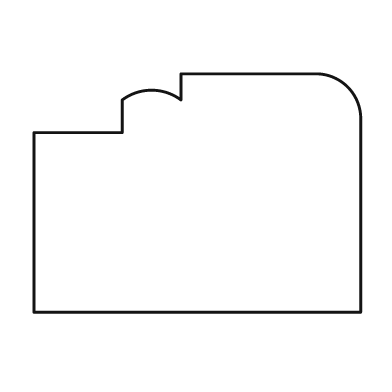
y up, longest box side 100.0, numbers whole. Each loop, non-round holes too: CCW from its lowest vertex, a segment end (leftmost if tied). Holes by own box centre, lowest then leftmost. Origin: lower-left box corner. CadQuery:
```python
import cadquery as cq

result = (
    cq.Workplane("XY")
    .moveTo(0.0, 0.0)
    .lineTo(100.0, 0.0)
    .lineTo(100.0, 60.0)
    .threePointArc((96.0, 69.0), (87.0, 73.0))
    .lineTo(45.0, 73.0)
    .lineTo(45.0, 65.0)
    .threePointArc((36.0, 68.0), (27.0, 65.0))
    .lineTo(27.0, 55.0)
    .lineTo(0.0, 55.0)
    .close()
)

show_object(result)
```